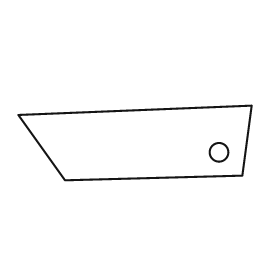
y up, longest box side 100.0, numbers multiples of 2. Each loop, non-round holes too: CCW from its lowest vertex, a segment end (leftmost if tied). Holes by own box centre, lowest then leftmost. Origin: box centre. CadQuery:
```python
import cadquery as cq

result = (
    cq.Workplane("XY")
    .moveTo(-30.0, -16.0)
    .lineTo(46.0, -14.0)
    .lineTo(50.0, 16.0)
    .lineTo(-50.0, 12.0)
    .close()
    .moveTo(36.0, -4.0)
    .circle(4.0)
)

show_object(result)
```